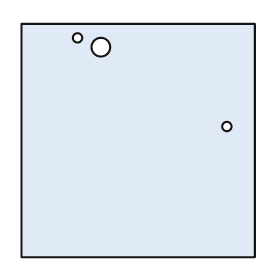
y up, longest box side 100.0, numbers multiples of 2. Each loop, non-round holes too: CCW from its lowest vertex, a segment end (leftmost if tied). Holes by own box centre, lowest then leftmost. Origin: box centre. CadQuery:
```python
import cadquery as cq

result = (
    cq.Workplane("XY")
    .moveTo(-50.0, -50.0)
    .lineTo(50.0, -50.0)
    .lineTo(50.0, 50.0)
    .lineTo(-50.0, 50.0)
    .close()
    .moveTo(38.0, 6.0)
    .circle(2.0)
    .moveTo(-16.0, 40.0)
    .circle(4.0)
    .moveTo(-26.0, 44.0)
    .circle(2.0)
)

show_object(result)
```